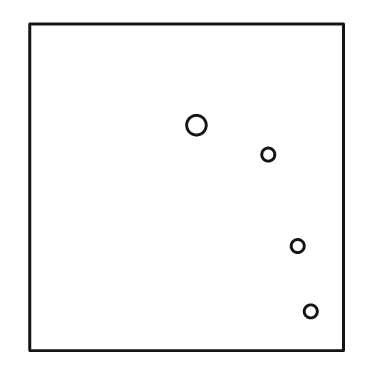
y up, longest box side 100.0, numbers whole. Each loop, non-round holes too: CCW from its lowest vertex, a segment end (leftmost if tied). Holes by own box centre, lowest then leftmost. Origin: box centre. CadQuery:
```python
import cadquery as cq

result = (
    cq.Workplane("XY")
    .moveTo(-48.0, -50.0)
    .lineTo(48.0, -50.0)
    .lineTo(48.0, 50.0)
    .lineTo(-48.0, 50.0)
    .close()
    .moveTo(38.0, -38.0)
    .circle(2.0)
    .moveTo(34.0, -18.0)
    .circle(2.0)
    .moveTo(25.0, 10.0)
    .circle(2.0)
    .moveTo(3.0, 19.0)
    .circle(3.0)
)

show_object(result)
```